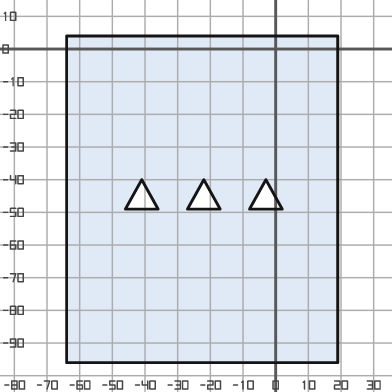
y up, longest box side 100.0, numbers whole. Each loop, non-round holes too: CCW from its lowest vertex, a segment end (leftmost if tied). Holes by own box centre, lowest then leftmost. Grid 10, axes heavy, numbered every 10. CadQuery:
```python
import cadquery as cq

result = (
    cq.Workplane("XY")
    .moveTo(-64.0, -96.0)
    .lineTo(19.0, -96.0)
    .lineTo(19.0, 4.0)
    .lineTo(-64.0, 4.0)
    .close()
    .moveTo(-46.0, -49.0)
    .lineTo(-36.0, -49.0)
    .lineTo(-41.0, -40.0)
    .close()
    .moveTo(-27.0, -49.0)
    .lineTo(-17.0, -49.0)
    .lineTo(-22.0, -40.0)
    .close()
    .moveTo(-8.0, -49.0)
    .lineTo(2.0, -49.0)
    .lineTo(-3.0, -40.0)
    .close()
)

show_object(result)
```